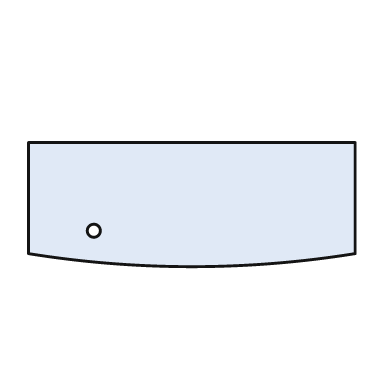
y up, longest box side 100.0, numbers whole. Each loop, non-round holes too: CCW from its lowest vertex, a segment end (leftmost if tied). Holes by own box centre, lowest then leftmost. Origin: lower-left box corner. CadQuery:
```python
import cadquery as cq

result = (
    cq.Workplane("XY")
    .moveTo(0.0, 4.0)
    .threePointArc((50.0, 0.0), (100.0, 4.0))
    .lineTo(100.0, 38.0)
    .lineTo(0.0, 38.0)
    .close()
    .moveTo(20.0, 11.0)
    .circle(2.0)
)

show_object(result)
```